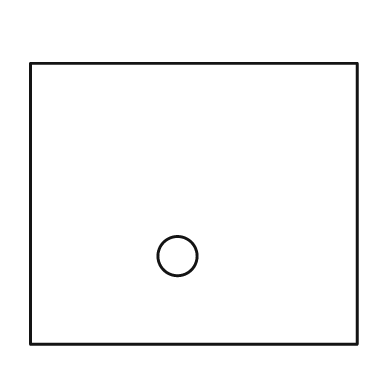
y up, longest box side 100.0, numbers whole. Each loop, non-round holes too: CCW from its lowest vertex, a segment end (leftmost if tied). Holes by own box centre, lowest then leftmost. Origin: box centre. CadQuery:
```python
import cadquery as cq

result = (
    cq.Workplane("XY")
    .moveTo(-50.0, -43.0)
    .lineTo(50.0, -43.0)
    .lineTo(50.0, 43.0)
    .lineTo(-50.0, 43.0)
    .close()
    .moveTo(-5.0, -16.0)
    .circle(6.0)
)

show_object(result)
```